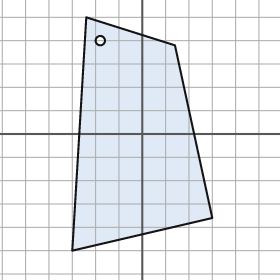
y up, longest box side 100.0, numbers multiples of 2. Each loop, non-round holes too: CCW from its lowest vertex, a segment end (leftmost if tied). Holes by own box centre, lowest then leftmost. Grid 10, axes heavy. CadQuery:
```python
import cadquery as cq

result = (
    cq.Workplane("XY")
    .moveTo(-30.0, -50.0)
    .lineTo(30.0, -36.0)
    .lineTo(14.0, 38.0)
    .lineTo(-24.0, 50.0)
    .close()
    .moveTo(-18.0, 40.0)
    .circle(2.0)
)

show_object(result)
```